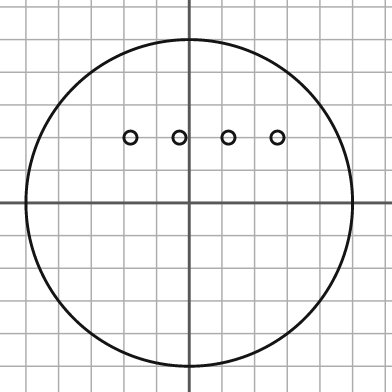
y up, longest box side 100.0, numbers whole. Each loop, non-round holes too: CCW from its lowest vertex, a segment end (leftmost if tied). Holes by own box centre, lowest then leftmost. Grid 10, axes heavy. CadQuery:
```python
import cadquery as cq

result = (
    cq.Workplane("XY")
    .moveTo(0.0, 0.0)
    .circle(50.0)
    .moveTo(-18.0, 20.0)
    .circle(2.0)
    .moveTo(-3.0, 20.0)
    .circle(2.0)
    .moveTo(12.0, 20.0)
    .circle(2.0)
    .moveTo(27.0, 20.0)
    .circle(2.0)
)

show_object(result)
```